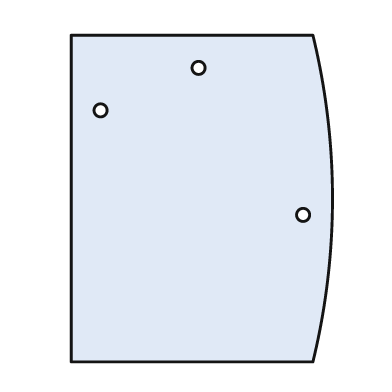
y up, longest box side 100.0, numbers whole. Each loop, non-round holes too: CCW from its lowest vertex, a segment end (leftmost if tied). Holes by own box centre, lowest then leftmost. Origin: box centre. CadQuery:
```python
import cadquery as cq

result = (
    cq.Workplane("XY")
    .moveTo(-40.0, -50.0)
    .lineTo(34.0, -50.0)
    .threePointArc((40.0, 0.0), (34.0, 50.0))
    .lineTo(-40.0, 50.0)
    .close()
    .moveTo(31.0, -5.0)
    .circle(2.0)
    .moveTo(-31.0, 27.0)
    .circle(2.0)
    .moveTo(-1.0, 40.0)
    .circle(2.0)
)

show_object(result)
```